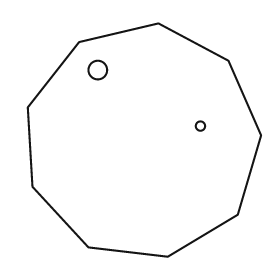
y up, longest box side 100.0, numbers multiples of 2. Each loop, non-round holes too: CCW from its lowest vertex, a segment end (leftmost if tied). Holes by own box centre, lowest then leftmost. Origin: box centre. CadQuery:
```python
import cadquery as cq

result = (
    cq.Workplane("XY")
    .moveTo(10.0, -50.0)
    .lineTo(40.0, -32.0)
    .lineTo(50.0, 2.0)
    .lineTo(36.0, 34.0)
    .lineTo(6.0, 50.0)
    .lineTo(-28.0, 42.0)
    .lineTo(-50.0, 14.0)
    .lineTo(-48.0, -20.0)
    .lineTo(-24.0, -46.0)
    .close()
    .moveTo(24.0, 6.0)
    .circle(2.0)
    .moveTo(-20.0, 30.0)
    .circle(4.0)
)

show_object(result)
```